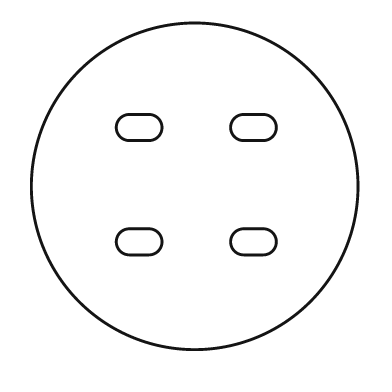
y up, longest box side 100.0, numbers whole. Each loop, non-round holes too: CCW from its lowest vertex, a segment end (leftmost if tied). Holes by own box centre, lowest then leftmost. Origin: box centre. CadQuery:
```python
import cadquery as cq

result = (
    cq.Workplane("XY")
    .moveTo(0.0, 0.0)
    .circle(50.0)
    .moveTo(-20.0, -21.0)
    .lineTo(-14.0, -21.0)
    .threePointArc((-10.0, -17.0), (-14.0, -13.0))
    .lineTo(-20.0, -13.0)
    .threePointArc((-24.0, -17.0), (-20.0, -21.0))
    .close()
    .moveTo(15.0, -21.0)
    .lineTo(21.0, -21.0)
    .threePointArc((25.0, -17.0), (21.0, -13.0))
    .lineTo(15.0, -13.0)
    .threePointArc((11.0, -17.0), (15.0, -21.0))
    .close()
    .moveTo(-20.0, 14.0)
    .lineTo(-14.0, 14.0)
    .threePointArc((-10.0, 18.0), (-14.0, 22.0))
    .lineTo(-20.0, 22.0)
    .threePointArc((-24.0, 18.0), (-20.0, 14.0))
    .close()
    .moveTo(15.0, 14.0)
    .lineTo(21.0, 14.0)
    .threePointArc((25.0, 18.0), (21.0, 22.0))
    .lineTo(15.0, 22.0)
    .threePointArc((11.0, 18.0), (15.0, 14.0))
    .close()
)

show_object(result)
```